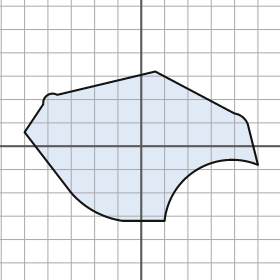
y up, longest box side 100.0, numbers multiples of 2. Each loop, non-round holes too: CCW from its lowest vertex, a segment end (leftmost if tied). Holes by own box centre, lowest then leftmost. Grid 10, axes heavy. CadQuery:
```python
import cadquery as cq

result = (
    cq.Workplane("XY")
    .moveTo(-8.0, -32.0)
    .lineTo(10.0, -32.0)
    .threePointArc((24.0, -10.0), (50.0, -8.0))
    .lineTo(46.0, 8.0)
    .threePointArc((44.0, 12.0), (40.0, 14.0))
    .lineTo(6.0, 32.0)
    .lineTo(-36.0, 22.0)
    .threePointArc((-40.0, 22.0), (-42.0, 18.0))
    .lineTo(-50.0, 6.0)
    .lineTo(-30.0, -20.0)
    .threePointArc((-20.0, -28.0), (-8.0, -32.0))
    .close()
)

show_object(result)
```